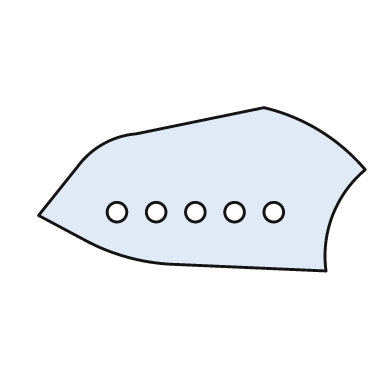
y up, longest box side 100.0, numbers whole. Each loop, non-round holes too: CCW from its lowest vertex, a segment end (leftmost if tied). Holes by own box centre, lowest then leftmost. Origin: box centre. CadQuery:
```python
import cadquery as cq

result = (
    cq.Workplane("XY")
    .moveTo(38.0, -25.0)
    .threePointArc((40.0, -8.0), (50.0, 6.0))
    .threePointArc((36.0, 18.0), (19.0, 25.0))
    .lineTo(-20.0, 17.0)
    .threePointArc((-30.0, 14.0), (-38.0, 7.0))
    .lineTo(-50.0, -8.0)
    .lineTo(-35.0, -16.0)
    .threePointArc((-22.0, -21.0), (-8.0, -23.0))
    .close()
    .moveTo(-26.0, -7.0)
    .circle(3.0)
    .moveTo(-14.0, -7.0)
    .circle(3.0)
    .moveTo(-2.0, -7.0)
    .circle(3.0)
    .moveTo(10.0, -7.0)
    .circle(3.0)
    .moveTo(22.0, -7.0)
    .circle(3.0)
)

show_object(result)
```